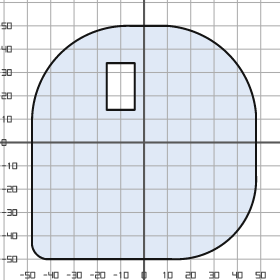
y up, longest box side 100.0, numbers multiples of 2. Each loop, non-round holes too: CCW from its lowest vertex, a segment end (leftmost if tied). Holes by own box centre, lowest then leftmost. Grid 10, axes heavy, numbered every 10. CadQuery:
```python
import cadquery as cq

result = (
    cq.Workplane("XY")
    .moveTo(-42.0, -50.0)
    .lineTo(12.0, -50.0)
    .threePointArc((38.0, -40.0), (48.0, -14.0))
    .lineTo(48.0, 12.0)
    .threePointArc((36.0, 38.0), (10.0, 50.0))
    .lineTo(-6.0, 50.0)
    .threePointArc((-36.0, 38.0), (-48.0, 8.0))
    .lineTo(-48.0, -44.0)
    .threePointArc((-46.0, -48.0), (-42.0, -50.0))
    .close()
    .moveTo(-16.0, 14.0)
    .lineTo(-4.0, 14.0)
    .lineTo(-4.0, 34.0)
    .lineTo(-16.0, 34.0)
    .close()
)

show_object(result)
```